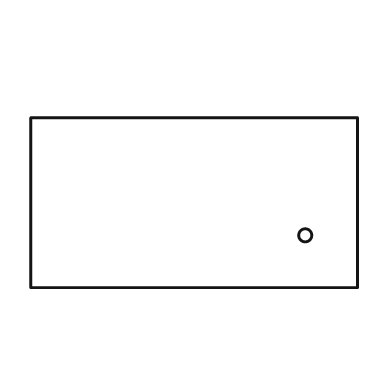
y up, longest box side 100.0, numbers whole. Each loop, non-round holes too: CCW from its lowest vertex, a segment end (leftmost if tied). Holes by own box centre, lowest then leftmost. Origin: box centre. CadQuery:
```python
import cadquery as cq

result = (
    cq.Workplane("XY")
    .moveTo(-50.0, -26.0)
    .lineTo(50.0, -26.0)
    .lineTo(50.0, 26.0)
    .lineTo(-50.0, 26.0)
    .close()
    .moveTo(34.0, -10.0)
    .circle(2.0)
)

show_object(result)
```